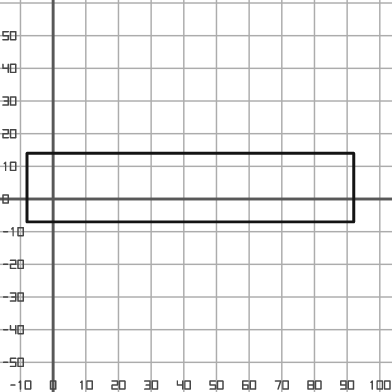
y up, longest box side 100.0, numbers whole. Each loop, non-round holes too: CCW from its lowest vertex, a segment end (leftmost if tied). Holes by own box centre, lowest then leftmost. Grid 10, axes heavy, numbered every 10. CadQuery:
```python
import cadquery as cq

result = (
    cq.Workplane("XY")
    .moveTo(-8.0, -7.0)
    .lineTo(92.0, -7.0)
    .lineTo(92.0, 14.0)
    .lineTo(-8.0, 14.0)
    .close()
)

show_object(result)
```